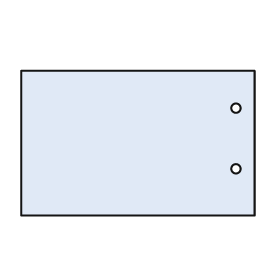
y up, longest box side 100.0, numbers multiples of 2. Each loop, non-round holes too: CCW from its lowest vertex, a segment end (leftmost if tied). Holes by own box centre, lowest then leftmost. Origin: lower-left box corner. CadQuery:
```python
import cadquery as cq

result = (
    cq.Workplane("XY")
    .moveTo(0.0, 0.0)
    .lineTo(100.0, 0.0)
    .lineTo(100.0, 62.0)
    .lineTo(0.0, 62.0)
    .close()
    .moveTo(92.0, 20.0)
    .circle(2.0)
    .moveTo(92.0, 46.0)
    .circle(2.0)
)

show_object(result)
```